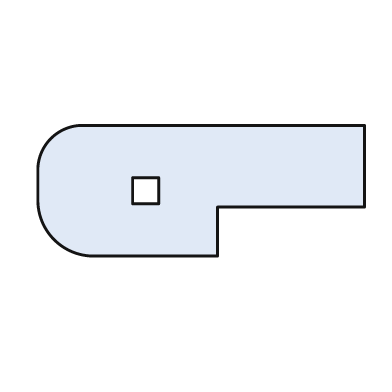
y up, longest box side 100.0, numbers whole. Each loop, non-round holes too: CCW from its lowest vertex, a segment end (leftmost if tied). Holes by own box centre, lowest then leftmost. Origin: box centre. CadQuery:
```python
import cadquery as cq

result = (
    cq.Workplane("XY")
    .moveTo(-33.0, -20.0)
    .lineTo(5.0, -20.0)
    .lineTo(5.0, -5.0)
    .lineTo(50.0, -5.0)
    .lineTo(50.0, 20.0)
    .lineTo(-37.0, 20.0)
    .threePointArc((-46.0, 16.0), (-50.0, 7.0))
    .lineTo(-50.0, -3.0)
    .threePointArc((-45.0, -15.0), (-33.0, -20.0))
    .close()
    .moveTo(-21.0, -4.0)
    .lineTo(-13.0, -4.0)
    .lineTo(-13.0, 4.0)
    .lineTo(-21.0, 4.0)
    .close()
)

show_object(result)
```